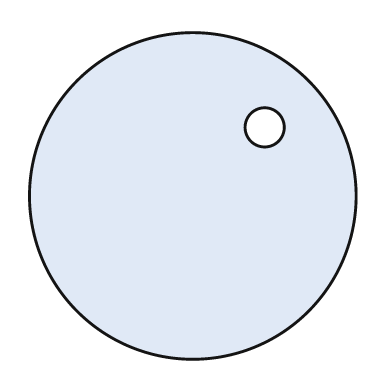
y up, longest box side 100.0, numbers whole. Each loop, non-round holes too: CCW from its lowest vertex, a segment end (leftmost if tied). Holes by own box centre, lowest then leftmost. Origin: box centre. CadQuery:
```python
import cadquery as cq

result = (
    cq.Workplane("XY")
    .moveTo(0.0, 0.0)
    .circle(50.0)
    .moveTo(22.0, 21.0)
    .circle(6.0)
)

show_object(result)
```